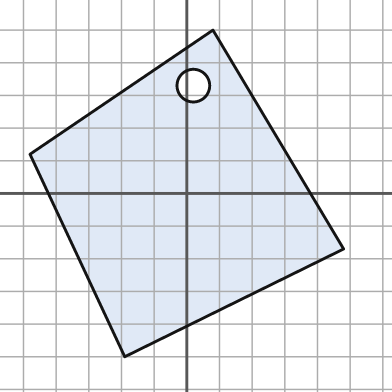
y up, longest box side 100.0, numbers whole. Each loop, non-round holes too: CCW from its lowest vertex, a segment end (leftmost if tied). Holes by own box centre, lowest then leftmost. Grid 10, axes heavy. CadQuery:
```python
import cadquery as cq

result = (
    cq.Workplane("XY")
    .moveTo(-19.0, -50.0)
    .lineTo(48.0, -17.0)
    .lineTo(8.0, 50.0)
    .lineTo(-48.0, 12.0)
    .close()
    .moveTo(2.0, 33.0)
    .circle(5.0)
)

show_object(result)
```